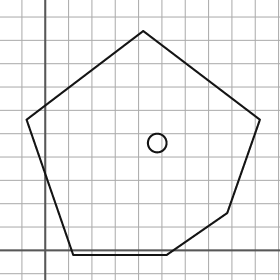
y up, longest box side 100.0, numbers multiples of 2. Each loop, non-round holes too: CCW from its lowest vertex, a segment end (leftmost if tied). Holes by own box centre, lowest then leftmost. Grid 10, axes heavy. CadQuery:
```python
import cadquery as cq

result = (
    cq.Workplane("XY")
    .moveTo(12.0, -2.0)
    .lineTo(52.0, -2.0)
    .lineTo(78.0, 16.0)
    .lineTo(92.0, 56.0)
    .lineTo(42.0, 94.0)
    .lineTo(-8.0, 56.0)
    .close()
    .moveTo(48.0, 46.0)
    .circle(4.0)
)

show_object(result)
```